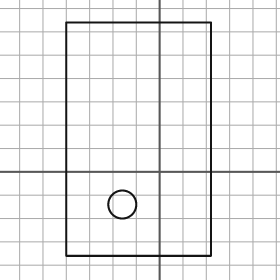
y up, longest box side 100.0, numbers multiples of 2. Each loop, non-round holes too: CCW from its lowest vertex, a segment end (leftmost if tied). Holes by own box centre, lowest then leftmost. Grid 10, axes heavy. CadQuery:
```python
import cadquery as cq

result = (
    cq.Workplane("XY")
    .moveTo(-40.0, -36.0)
    .lineTo(22.0, -36.0)
    .lineTo(22.0, 64.0)
    .lineTo(-40.0, 64.0)
    .close()
    .moveTo(-16.0, -14.0)
    .circle(6.0)
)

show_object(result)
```